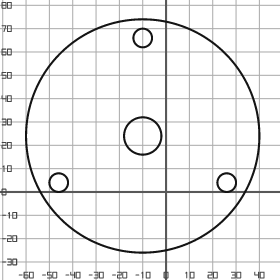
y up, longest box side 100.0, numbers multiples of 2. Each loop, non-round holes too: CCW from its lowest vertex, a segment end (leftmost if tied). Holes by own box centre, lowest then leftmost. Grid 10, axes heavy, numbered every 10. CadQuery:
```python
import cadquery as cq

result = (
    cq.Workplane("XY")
    .moveTo(-10.0, 24.0)
    .circle(50.0)
    .moveTo(-46.0, 4.0)
    .circle(4.0)
    .moveTo(26.0, 4.0)
    .circle(4.0)
    .moveTo(-10.0, 24.0)
    .circle(8.0)
    .moveTo(-10.0, 66.0)
    .circle(4.0)
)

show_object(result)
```